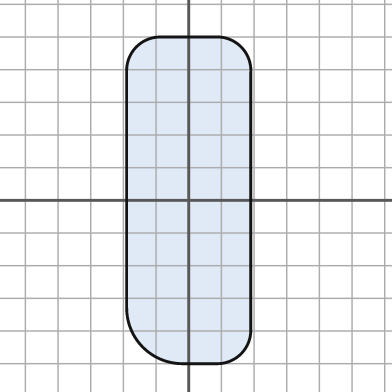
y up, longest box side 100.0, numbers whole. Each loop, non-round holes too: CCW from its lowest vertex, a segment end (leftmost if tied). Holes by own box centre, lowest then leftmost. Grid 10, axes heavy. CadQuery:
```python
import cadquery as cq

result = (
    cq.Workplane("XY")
    .moveTo(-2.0, -50.0)
    .lineTo(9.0, -50.0)
    .threePointArc((16.0, -47.0), (19.0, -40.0))
    .lineTo(19.0, 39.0)
    .threePointArc((16.0, 47.0), (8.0, 50.0))
    .lineTo(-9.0, 50.0)
    .threePointArc((-16.0, 47.0), (-19.0, 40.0))
    .lineTo(-19.0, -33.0)
    .threePointArc((-14.0, -45.0), (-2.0, -50.0))
    .close()
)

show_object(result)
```